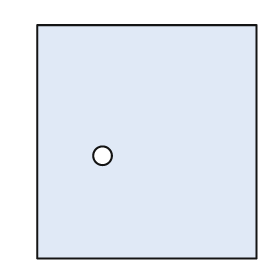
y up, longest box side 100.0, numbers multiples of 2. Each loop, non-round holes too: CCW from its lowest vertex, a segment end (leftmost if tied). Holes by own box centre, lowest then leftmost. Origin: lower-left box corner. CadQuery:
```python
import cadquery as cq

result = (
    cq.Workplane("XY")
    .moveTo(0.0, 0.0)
    .lineTo(94.0, 0.0)
    .lineTo(94.0, 100.0)
    .lineTo(0.0, 100.0)
    .close()
    .moveTo(28.0, 44.0)
    .circle(4.0)
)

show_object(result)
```